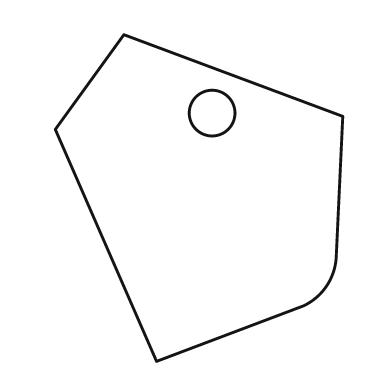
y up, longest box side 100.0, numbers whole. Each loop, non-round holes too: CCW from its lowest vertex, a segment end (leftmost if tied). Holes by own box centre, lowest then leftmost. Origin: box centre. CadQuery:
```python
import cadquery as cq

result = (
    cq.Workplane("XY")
    .moveTo(-13.0, -50.0)
    .lineTo(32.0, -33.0)
    .threePointArc((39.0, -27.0), (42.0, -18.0))
    .lineTo(44.0, 25.0)
    .lineTo(-23.0, 50.0)
    .lineTo(-44.0, 21.0)
    .close()
    .moveTo(4.0, 26.0)
    .circle(7.0)
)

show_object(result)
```